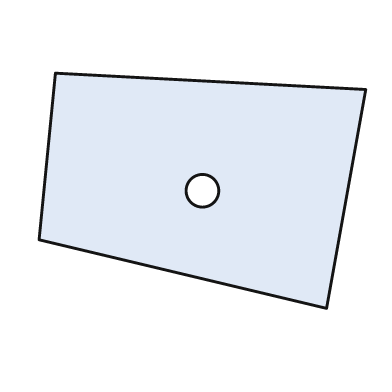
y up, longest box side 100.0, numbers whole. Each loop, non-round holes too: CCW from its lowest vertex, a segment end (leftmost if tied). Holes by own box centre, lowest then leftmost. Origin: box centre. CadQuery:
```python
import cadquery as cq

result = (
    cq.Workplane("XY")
    .moveTo(38.0, -36.0)
    .lineTo(50.0, 31.0)
    .lineTo(-45.0, 36.0)
    .lineTo(-50.0, -15.0)
    .close()
    .moveTo(0.0, 0.0)
    .circle(5.0)
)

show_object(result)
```